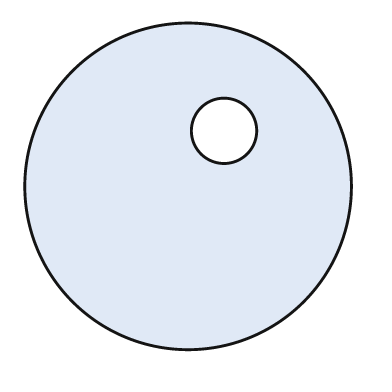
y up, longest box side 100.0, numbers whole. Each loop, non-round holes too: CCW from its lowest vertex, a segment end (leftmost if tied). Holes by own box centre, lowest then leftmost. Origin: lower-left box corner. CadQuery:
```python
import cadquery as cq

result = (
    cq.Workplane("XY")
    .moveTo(50.0, 50.0)
    .circle(50.0)
    .moveTo(61.0, 67.0)
    .circle(10.0)
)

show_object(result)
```